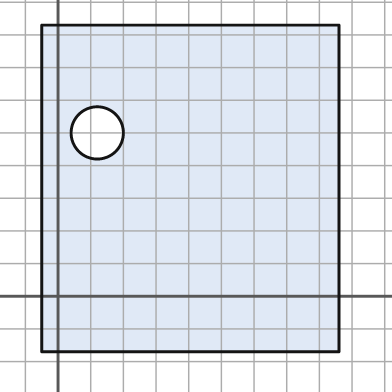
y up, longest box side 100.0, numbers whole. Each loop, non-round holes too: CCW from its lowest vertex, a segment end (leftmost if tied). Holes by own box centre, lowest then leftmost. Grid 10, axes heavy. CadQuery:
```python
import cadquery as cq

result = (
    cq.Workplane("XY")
    .moveTo(-5.0, -17.0)
    .lineTo(86.0, -17.0)
    .lineTo(86.0, 83.0)
    .lineTo(-5.0, 83.0)
    .close()
    .moveTo(12.0, 50.0)
    .circle(8.0)
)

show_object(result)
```